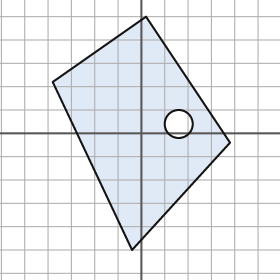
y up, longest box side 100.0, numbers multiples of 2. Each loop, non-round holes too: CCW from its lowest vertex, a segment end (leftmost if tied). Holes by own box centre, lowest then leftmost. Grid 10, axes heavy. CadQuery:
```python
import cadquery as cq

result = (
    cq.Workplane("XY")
    .moveTo(-4.0, -50.0)
    .lineTo(38.0, -4.0)
    .lineTo(2.0, 50.0)
    .lineTo(-38.0, 22.0)
    .close()
    .moveTo(16.0, 4.0)
    .circle(6.0)
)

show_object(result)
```